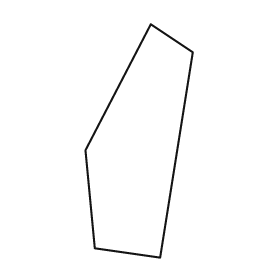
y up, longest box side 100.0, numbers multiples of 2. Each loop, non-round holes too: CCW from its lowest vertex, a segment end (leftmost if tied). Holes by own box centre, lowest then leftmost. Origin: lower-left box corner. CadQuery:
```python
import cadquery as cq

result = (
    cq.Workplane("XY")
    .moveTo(32.0, 0.0)
    .lineTo(46.0, 88.0)
    .lineTo(28.0, 100.0)
    .lineTo(0.0, 46.0)
    .lineTo(4.0, 4.0)
    .close()
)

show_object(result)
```